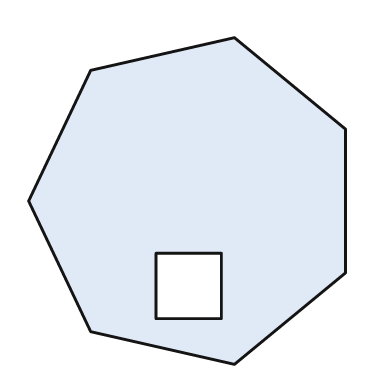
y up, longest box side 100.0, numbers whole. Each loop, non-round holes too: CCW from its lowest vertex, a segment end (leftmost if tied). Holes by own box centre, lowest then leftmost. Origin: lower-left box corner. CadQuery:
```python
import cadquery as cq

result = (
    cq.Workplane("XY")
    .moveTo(63.0, 0.0)
    .lineTo(97.0, 28.0)
    .lineTo(97.0, 72.0)
    .lineTo(63.0, 100.0)
    .lineTo(19.0, 90.0)
    .lineTo(0.0, 50.0)
    .lineTo(19.0, 10.0)
    .close()
    .moveTo(39.0, 14.0)
    .lineTo(59.0, 14.0)
    .lineTo(59.0, 34.0)
    .lineTo(39.0, 34.0)
    .close()
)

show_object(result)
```